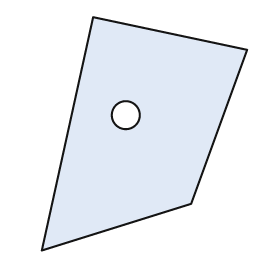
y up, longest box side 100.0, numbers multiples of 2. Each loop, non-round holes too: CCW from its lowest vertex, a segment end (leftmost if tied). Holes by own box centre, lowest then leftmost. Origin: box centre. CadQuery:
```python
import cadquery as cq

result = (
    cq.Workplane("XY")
    .moveTo(-44.0, -50.0)
    .lineTo(20.0, -30.0)
    .lineTo(44.0, 36.0)
    .lineTo(-22.0, 50.0)
    .close()
    .moveTo(-8.0, 8.0)
    .circle(6.0)
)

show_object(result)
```